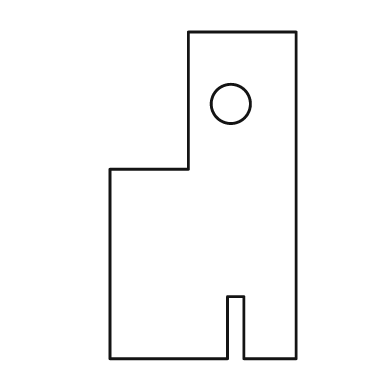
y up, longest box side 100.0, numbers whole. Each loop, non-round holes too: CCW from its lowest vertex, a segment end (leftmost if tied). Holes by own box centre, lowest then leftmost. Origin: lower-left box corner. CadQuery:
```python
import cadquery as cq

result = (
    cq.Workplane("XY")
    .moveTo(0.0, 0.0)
    .lineTo(36.0, 0.0)
    .lineTo(36.0, 19.0)
    .lineTo(41.0, 19.0)
    .lineTo(41.0, 0.0)
    .lineTo(57.0, 0.0)
    .lineTo(57.0, 100.0)
    .lineTo(24.0, 100.0)
    .lineTo(24.0, 58.0)
    .lineTo(0.0, 58.0)
    .close()
    .moveTo(37.0, 78.0)
    .circle(6.0)
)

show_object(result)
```